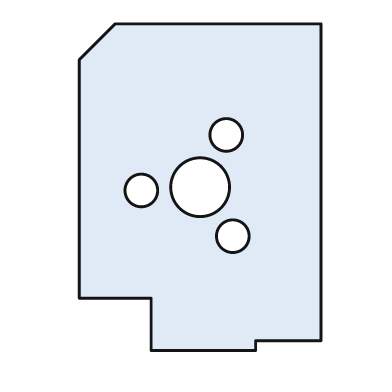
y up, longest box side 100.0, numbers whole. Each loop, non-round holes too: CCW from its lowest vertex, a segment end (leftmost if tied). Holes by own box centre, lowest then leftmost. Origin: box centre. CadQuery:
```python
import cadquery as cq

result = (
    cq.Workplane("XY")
    .moveTo(-15.0, -50.0)
    .lineTo(17.0, -50.0)
    .lineTo(17.0, -47.0)
    .lineTo(37.0, -47.0)
    .lineTo(37.0, 50.0)
    .lineTo(-26.0, 50.0)
    .lineTo(-37.0, 39.0)
    .lineTo(-37.0, -34.0)
    .lineTo(-15.0, -34.0)
    .close()
    .moveTo(10.0, -15.0)
    .circle(5.0)
    .moveTo(-18.0, -1.0)
    .circle(5.0)
    .moveTo(0.0, 0.0)
    .circle(9.0)
    .moveTo(8.0, 16.0)
    .circle(5.0)
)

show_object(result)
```